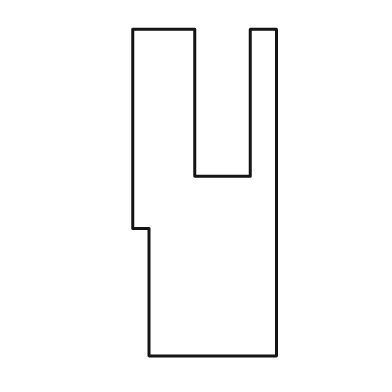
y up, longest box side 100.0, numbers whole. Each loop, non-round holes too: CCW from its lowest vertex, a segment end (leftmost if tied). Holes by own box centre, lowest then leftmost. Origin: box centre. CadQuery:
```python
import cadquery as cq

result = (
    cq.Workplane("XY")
    .moveTo(-17.0, -50.0)
    .lineTo(22.0, -50.0)
    .lineTo(22.0, 50.0)
    .lineTo(14.0, 50.0)
    .lineTo(14.0, 5.0)
    .lineTo(-3.0, 5.0)
    .lineTo(-3.0, 50.0)
    .lineTo(-22.0, 50.0)
    .lineTo(-22.0, -11.0)
    .lineTo(-17.0, -11.0)
    .close()
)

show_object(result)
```